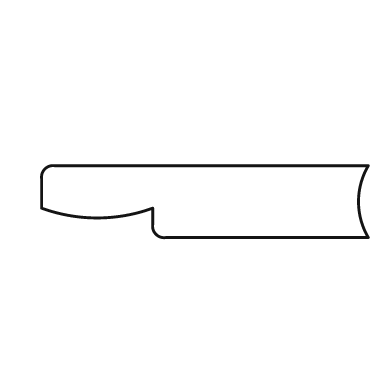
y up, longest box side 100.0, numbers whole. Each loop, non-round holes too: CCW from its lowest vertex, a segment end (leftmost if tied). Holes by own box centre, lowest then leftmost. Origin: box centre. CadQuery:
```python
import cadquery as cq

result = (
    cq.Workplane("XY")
    .moveTo(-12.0, -11.0)
    .lineTo(50.0, -11.0)
    .threePointArc((47.0, 0.0), (50.0, 11.0))
    .lineTo(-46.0, 11.0)
    .threePointArc((-49.0, 10.0), (-50.0, 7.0))
    .lineTo(-50.0, -2.0)
    .threePointArc((-33.0, -5.0), (-16.0, -2.0))
    .lineTo(-16.0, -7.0)
    .threePointArc((-15.0, -10.0), (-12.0, -11.0))
    .close()
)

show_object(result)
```